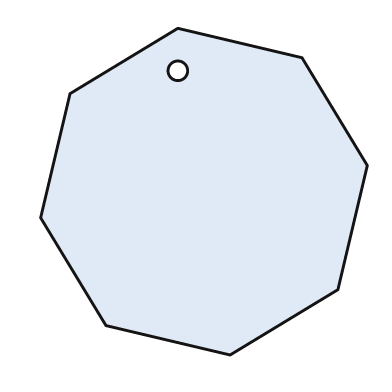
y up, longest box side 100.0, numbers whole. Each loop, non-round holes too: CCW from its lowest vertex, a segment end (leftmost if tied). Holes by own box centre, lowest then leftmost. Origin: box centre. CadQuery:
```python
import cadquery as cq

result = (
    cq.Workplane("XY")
    .moveTo(8.0, -50.0)
    .lineTo(41.0, -30.0)
    .lineTo(50.0, 8.0)
    .lineTo(30.0, 41.0)
    .lineTo(-8.0, 50.0)
    .lineTo(-41.0, 30.0)
    .lineTo(-50.0, -8.0)
    .lineTo(-30.0, -41.0)
    .close()
    .moveTo(-8.0, 37.0)
    .circle(3.0)
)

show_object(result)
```